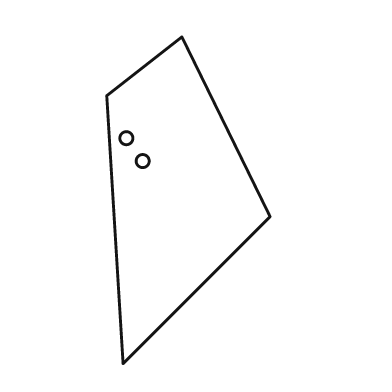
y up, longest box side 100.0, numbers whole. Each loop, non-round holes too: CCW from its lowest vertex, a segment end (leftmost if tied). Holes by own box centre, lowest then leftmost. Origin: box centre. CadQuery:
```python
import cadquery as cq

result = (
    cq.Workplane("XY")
    .moveTo(-20.0, -50.0)
    .lineTo(25.0, -5.0)
    .lineTo(-2.0, 50.0)
    .lineTo(-25.0, 32.0)
    .close()
    .moveTo(-14.0, 12.0)
    .circle(2.0)
    .moveTo(-19.0, 19.0)
    .circle(2.0)
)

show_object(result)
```